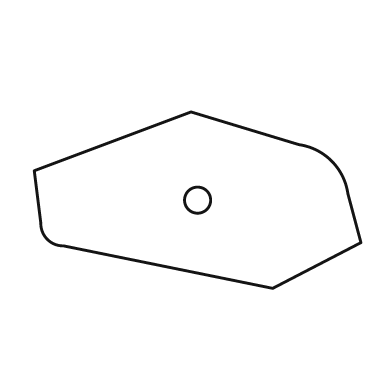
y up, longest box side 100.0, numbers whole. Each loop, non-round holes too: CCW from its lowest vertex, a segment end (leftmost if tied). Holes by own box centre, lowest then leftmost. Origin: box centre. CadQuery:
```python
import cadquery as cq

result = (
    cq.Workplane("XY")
    .moveTo(23.0, -27.0)
    .lineTo(50.0, -13.0)
    .lineTo(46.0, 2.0)
    .threePointArc((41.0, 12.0), (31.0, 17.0))
    .lineTo(-2.0, 27.0)
    .lineTo(-50.0, 9.0)
    .lineTo(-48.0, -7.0)
    .threePointArc((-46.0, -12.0), (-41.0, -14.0))
    .close()
    .moveTo(0.0, 0.0)
    .circle(4.0)
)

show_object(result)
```